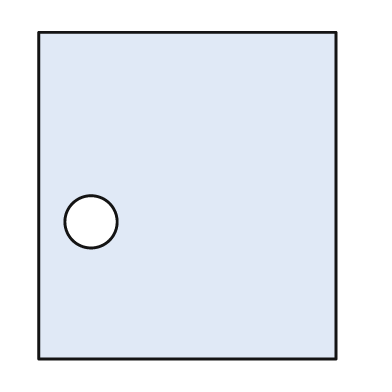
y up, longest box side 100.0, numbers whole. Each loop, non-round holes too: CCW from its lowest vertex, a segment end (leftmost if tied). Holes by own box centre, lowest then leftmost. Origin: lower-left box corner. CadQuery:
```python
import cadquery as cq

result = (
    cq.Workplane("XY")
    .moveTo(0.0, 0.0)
    .lineTo(91.0, 0.0)
    .lineTo(91.0, 100.0)
    .lineTo(0.0, 100.0)
    .close()
    .moveTo(16.0, 42.0)
    .circle(8.0)
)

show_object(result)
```